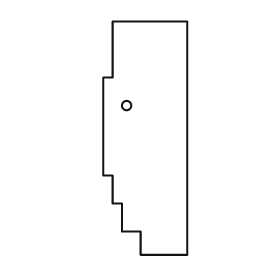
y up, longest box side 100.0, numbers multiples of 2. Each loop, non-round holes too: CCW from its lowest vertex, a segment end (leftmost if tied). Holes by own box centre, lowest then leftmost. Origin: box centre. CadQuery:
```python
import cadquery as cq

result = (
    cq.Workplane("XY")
    .moveTo(-2.0, -50.0)
    .lineTo(18.0, -50.0)
    .lineTo(18.0, 50.0)
    .lineTo(-14.0, 50.0)
    .lineTo(-14.0, 26.0)
    .lineTo(-18.0, 26.0)
    .lineTo(-18.0, -16.0)
    .lineTo(-14.0, -16.0)
    .lineTo(-14.0, -28.0)
    .lineTo(-10.0, -28.0)
    .lineTo(-10.0, -40.0)
    .lineTo(-2.0, -40.0)
    .close()
    .moveTo(-8.0, 14.0)
    .circle(2.0)
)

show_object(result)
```